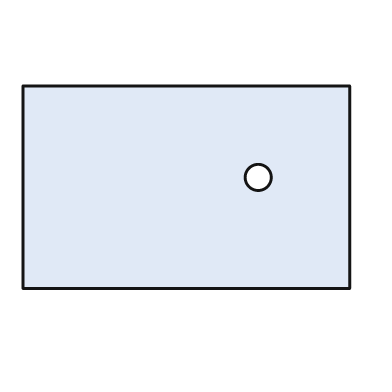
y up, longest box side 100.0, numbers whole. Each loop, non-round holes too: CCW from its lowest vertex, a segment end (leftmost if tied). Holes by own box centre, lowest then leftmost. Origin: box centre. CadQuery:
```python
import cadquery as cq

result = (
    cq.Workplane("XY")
    .moveTo(-50.0, -31.0)
    .lineTo(50.0, -31.0)
    .lineTo(50.0, 31.0)
    .lineTo(-50.0, 31.0)
    .close()
    .moveTo(22.0, 3.0)
    .circle(4.0)
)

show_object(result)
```